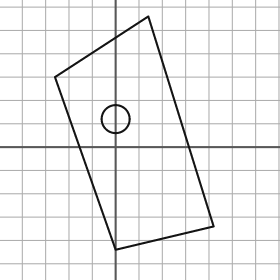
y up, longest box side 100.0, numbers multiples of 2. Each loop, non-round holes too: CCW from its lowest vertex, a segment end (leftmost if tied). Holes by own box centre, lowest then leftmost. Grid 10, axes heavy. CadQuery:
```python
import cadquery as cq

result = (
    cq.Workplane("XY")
    .moveTo(0.0, -44.0)
    .lineTo(42.0, -34.0)
    .lineTo(14.0, 56.0)
    .lineTo(-26.0, 30.0)
    .close()
    .moveTo(0.0, 12.0)
    .circle(6.0)
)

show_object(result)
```